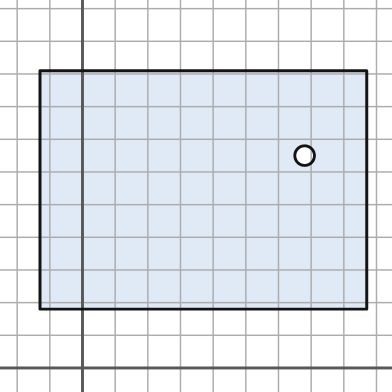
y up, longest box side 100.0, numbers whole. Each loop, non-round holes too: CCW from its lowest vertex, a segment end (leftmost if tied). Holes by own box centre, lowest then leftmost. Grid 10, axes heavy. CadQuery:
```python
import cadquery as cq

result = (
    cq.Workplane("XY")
    .moveTo(-13.0, 18.0)
    .lineTo(87.0, 18.0)
    .lineTo(87.0, 91.0)
    .lineTo(-13.0, 91.0)
    .close()
    .moveTo(68.0, 65.0)
    .circle(3.0)
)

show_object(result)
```